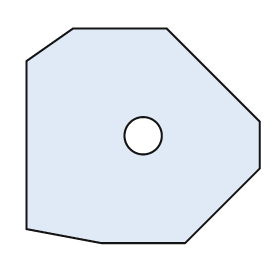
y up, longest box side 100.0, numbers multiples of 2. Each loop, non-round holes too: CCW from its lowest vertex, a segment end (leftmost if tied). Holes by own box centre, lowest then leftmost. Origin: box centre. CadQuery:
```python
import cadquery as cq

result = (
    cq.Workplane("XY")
    .moveTo(-18.0, -46.0)
    .lineTo(18.0, -46.0)
    .lineTo(50.0, -14.0)
    .lineTo(50.0, 6.0)
    .lineTo(10.0, 46.0)
    .lineTo(-30.0, 46.0)
    .lineTo(-50.0, 32.0)
    .lineTo(-50.0, -40.0)
    .close()
    .moveTo(0.0, 0.0)
    .circle(8.0)
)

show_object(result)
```